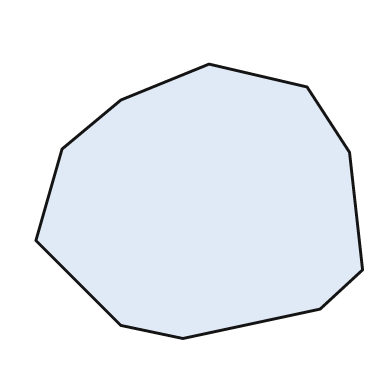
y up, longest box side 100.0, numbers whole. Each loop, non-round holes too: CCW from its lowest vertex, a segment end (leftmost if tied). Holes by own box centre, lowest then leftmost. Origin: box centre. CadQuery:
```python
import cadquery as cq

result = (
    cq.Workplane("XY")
    .moveTo(-5.0, -42.0)
    .lineTo(37.0, -33.0)
    .lineTo(50.0, -21.0)
    .lineTo(46.0, 15.0)
    .lineTo(33.0, 35.0)
    .lineTo(3.0, 42.0)
    .lineTo(-24.0, 31.0)
    .lineTo(-42.0, 16.0)
    .lineTo(-50.0, -12.0)
    .lineTo(-24.0, -38.0)
    .close()
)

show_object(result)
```